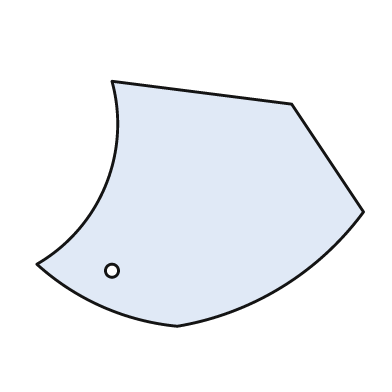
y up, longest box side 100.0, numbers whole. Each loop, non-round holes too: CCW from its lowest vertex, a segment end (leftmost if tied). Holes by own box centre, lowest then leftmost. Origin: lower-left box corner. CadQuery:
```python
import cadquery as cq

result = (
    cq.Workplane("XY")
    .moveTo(43.0, 0.0)
    .threePointArc((75.0, 12.0), (100.0, 35.0))
    .lineTo(78.0, 68.0)
    .lineTo(23.0, 75.0)
    .threePointArc((21.0, 43.0), (0.0, 19.0))
    .threePointArc((20.0, 6.0), (43.0, 0.0))
    .close()
    .moveTo(23.0, 17.0)
    .circle(2.0)
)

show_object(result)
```